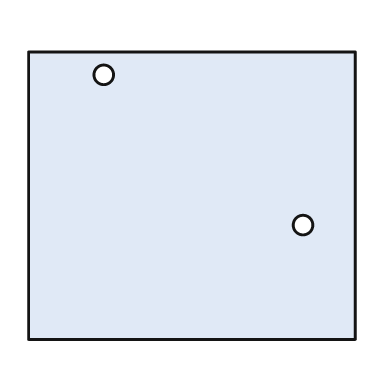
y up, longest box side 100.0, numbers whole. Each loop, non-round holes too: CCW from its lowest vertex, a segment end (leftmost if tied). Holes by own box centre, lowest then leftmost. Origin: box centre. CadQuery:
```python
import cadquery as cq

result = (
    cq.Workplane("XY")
    .moveTo(-50.0, -44.0)
    .lineTo(50.0, -44.0)
    .lineTo(50.0, 44.0)
    .lineTo(-50.0, 44.0)
    .close()
    .moveTo(34.0, -9.0)
    .circle(3.0)
    .moveTo(-27.0, 37.0)
    .circle(3.0)
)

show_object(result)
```